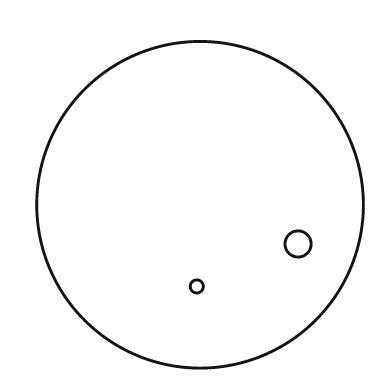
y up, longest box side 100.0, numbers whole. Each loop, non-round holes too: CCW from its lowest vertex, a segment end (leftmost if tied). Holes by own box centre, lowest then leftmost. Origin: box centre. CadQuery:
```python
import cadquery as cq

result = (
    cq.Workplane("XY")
    .moveTo(0.0, 0.0)
    .circle(50.0)
    .moveTo(-1.0, -25.0)
    .circle(2.0)
    .moveTo(30.0, -12.0)
    .circle(4.0)
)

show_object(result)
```